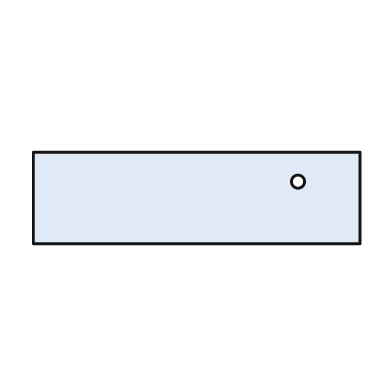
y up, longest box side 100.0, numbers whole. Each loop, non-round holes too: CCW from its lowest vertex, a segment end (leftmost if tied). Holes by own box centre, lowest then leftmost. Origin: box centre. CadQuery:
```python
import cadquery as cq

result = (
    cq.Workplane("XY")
    .moveTo(-50.0, -14.0)
    .lineTo(50.0, -14.0)
    .lineTo(50.0, 14.0)
    .lineTo(-50.0, 14.0)
    .close()
    .moveTo(31.0, 5.0)
    .circle(2.0)
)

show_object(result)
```